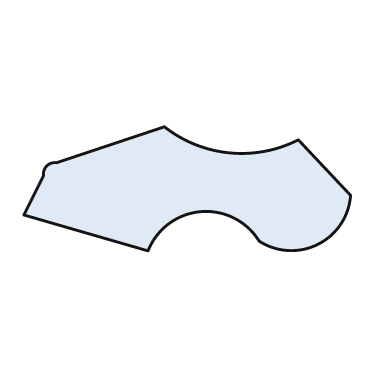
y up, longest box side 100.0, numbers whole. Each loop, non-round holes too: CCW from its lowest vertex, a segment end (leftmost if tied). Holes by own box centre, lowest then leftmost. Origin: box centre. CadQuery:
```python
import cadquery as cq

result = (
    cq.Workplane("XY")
    .moveTo(-12.0, -19.0)
    .threePointArc((4.0, -7.0), (22.0, -16.0))
    .threePointArc((40.0, -17.0), (50.0, -2.0))
    .lineTo(34.0, 15.0)
    .threePointArc((13.0, 11.0), (-7.0, 19.0))
    .lineTo(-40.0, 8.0)
    .threePointArc((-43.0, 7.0), (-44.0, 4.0))
    .lineTo(-50.0, -8.0)
    .close()
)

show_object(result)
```